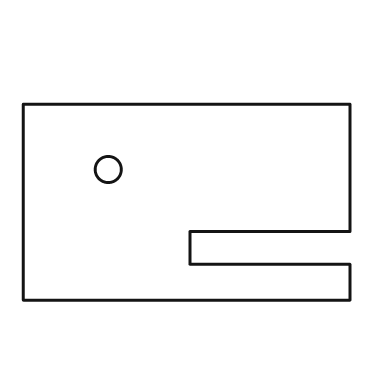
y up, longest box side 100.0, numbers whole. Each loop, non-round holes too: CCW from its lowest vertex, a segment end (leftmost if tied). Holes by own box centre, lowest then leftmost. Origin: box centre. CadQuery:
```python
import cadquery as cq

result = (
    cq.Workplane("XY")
    .moveTo(-50.0, -30.0)
    .lineTo(50.0, -30.0)
    .lineTo(50.0, -19.0)
    .lineTo(1.0, -19.0)
    .lineTo(1.0, -9.0)
    .lineTo(50.0, -9.0)
    .lineTo(50.0, 30.0)
    .lineTo(-50.0, 30.0)
    .close()
    .moveTo(-24.0, 10.0)
    .circle(4.0)
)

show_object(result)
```